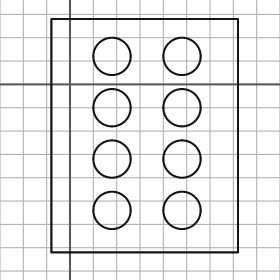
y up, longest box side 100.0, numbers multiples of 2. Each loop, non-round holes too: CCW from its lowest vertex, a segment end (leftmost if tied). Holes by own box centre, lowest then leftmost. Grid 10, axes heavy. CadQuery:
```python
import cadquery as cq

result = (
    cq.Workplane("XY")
    .moveTo(-8.0, -72.0)
    .lineTo(72.0, -72.0)
    .lineTo(72.0, 28.0)
    .lineTo(-8.0, 28.0)
    .close()
    .moveTo(18.0, -54.0)
    .circle(8.0)
    .moveTo(48.0, -54.0)
    .circle(8.0)
    .moveTo(18.0, -32.0)
    .circle(8.0)
    .moveTo(48.0, -32.0)
    .circle(8.0)
    .moveTo(18.0, -10.0)
    .circle(8.0)
    .moveTo(48.0, -10.0)
    .circle(8.0)
    .moveTo(18.0, 12.0)
    .circle(8.0)
    .moveTo(48.0, 12.0)
    .circle(8.0)
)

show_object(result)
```